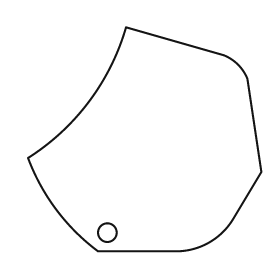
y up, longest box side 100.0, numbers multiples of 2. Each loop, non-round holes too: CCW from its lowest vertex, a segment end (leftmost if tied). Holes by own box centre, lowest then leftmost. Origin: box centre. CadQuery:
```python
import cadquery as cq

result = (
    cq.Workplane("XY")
    .moveTo(-20.0, -48.0)
    .lineTo(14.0, -48.0)
    .threePointArc((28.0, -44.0), (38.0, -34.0))
    .lineTo(50.0, -14.0)
    .lineTo(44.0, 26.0)
    .threePointArc((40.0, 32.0), (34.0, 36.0))
    .lineTo(-8.0, 48.0)
    .threePointArc((-24.0, 16.0), (-50.0, -8.0))
    .threePointArc((-38.0, -30.0), (-20.0, -48.0))
    .close()
    .moveTo(-16.0, -40.0)
    .circle(4.0)
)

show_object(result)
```